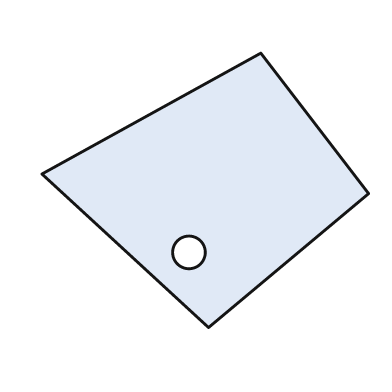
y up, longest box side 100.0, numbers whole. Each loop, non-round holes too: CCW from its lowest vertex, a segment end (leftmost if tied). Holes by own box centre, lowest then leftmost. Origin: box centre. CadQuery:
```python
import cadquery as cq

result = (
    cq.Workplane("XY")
    .moveTo(1.0, -42.0)
    .lineTo(50.0, -1.0)
    .lineTo(17.0, 42.0)
    .lineTo(-50.0, 5.0)
    .close()
    .moveTo(-5.0, -19.0)
    .circle(5.0)
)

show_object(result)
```